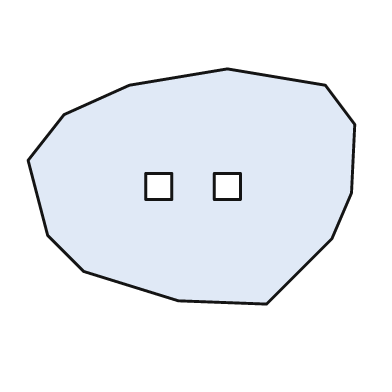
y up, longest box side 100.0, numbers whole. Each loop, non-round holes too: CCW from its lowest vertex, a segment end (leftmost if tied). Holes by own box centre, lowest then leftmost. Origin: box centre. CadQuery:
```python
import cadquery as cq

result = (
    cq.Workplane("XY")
    .moveTo(23.0, -36.0)
    .lineTo(43.0, -16.0)
    .lineTo(49.0, -2.0)
    .lineTo(50.0, 19.0)
    .lineTo(41.0, 31.0)
    .lineTo(11.0, 36.0)
    .lineTo(-19.0, 31.0)
    .lineTo(-39.0, 22.0)
    .lineTo(-50.0, 8.0)
    .lineTo(-44.0, -15.0)
    .lineTo(-33.0, -26.0)
    .lineTo(-4.0, -35.0)
    .close()
    .moveTo(-14.0, -4.0)
    .lineTo(-6.0, -4.0)
    .lineTo(-6.0, 4.0)
    .lineTo(-14.0, 4.0)
    .close()
    .moveTo(7.0, -4.0)
    .lineTo(15.0, -4.0)
    .lineTo(15.0, 4.0)
    .lineTo(7.0, 4.0)
    .close()
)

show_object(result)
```